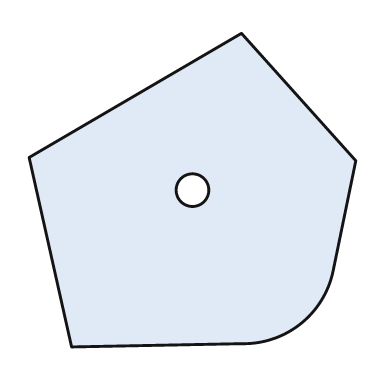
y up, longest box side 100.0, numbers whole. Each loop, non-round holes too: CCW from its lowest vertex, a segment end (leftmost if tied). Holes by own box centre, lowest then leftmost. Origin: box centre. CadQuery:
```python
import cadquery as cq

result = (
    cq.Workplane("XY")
    .moveTo(-37.0, -48.0)
    .lineTo(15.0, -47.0)
    .threePointArc((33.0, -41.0), (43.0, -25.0))
    .lineTo(50.0, 9.0)
    .lineTo(15.0, 48.0)
    .lineTo(-50.0, 10.0)
    .close()
    .moveTo(0.0, 0.0)
    .circle(5.0)
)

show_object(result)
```